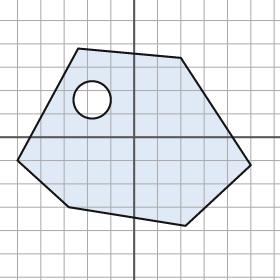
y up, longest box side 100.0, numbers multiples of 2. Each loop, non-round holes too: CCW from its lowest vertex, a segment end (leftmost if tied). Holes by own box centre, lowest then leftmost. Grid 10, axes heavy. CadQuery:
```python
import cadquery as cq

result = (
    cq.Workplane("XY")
    .moveTo(22.0, -38.0)
    .lineTo(50.0, -12.0)
    .lineTo(20.0, 34.0)
    .lineTo(-24.0, 38.0)
    .lineTo(-50.0, -10.0)
    .lineTo(-28.0, -30.0)
    .close()
    .moveTo(-18.0, 16.0)
    .circle(8.0)
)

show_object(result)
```